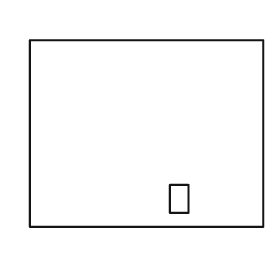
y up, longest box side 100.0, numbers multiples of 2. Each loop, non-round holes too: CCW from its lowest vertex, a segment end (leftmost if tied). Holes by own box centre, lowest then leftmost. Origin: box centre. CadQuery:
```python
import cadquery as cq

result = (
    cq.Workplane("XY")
    .moveTo(-50.0, -40.0)
    .lineTo(50.0, -40.0)
    .lineTo(50.0, 40.0)
    .lineTo(-50.0, 40.0)
    .close()
    .moveTo(10.0, -34.0)
    .lineTo(18.0, -34.0)
    .lineTo(18.0, -22.0)
    .lineTo(10.0, -22.0)
    .close()
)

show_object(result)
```